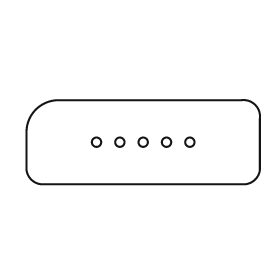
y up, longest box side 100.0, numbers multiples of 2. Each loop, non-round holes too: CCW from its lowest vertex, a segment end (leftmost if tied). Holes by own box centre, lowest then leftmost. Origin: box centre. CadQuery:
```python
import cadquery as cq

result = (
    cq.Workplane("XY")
    .moveTo(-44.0, -18.0)
    .lineTo(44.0, -18.0)
    .threePointArc((48.0, -16.0), (50.0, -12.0))
    .lineTo(50.0, 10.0)
    .threePointArc((48.0, 16.0), (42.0, 18.0))
    .lineTo(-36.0, 18.0)
    .threePointArc((-46.0, 14.0), (-50.0, 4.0))
    .lineTo(-50.0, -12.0)
    .threePointArc((-48.0, -16.0), (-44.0, -18.0))
    .close()
    .moveTo(-20.0, 0.0)
    .circle(2.0)
    .moveTo(-10.0, 0.0)
    .circle(2.0)
    .moveTo(0.0, 0.0)
    .circle(2.0)
    .moveTo(10.0, 0.0)
    .circle(2.0)
    .moveTo(20.0, 0.0)
    .circle(2.0)
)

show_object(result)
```